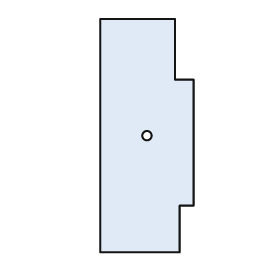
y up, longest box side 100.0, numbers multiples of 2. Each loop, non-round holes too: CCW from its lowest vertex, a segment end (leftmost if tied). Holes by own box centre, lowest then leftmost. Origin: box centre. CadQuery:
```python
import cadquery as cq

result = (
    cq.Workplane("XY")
    .moveTo(-20.0, -50.0)
    .lineTo(14.0, -50.0)
    .lineTo(14.0, -30.0)
    .lineTo(20.0, -30.0)
    .lineTo(20.0, 24.0)
    .lineTo(12.0, 24.0)
    .lineTo(12.0, 50.0)
    .lineTo(-20.0, 50.0)
    .close()
    .moveTo(0.0, 0.0)
    .circle(2.0)
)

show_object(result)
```